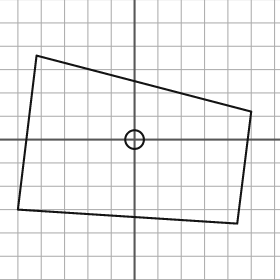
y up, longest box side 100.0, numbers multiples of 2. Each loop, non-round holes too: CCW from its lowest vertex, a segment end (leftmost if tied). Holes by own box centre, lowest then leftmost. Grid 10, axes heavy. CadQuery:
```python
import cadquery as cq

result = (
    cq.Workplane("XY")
    .moveTo(44.0, -36.0)
    .lineTo(50.0, 12.0)
    .lineTo(-42.0, 36.0)
    .lineTo(-50.0, -30.0)
    .close()
    .moveTo(0.0, 0.0)
    .circle(4.0)
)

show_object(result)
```